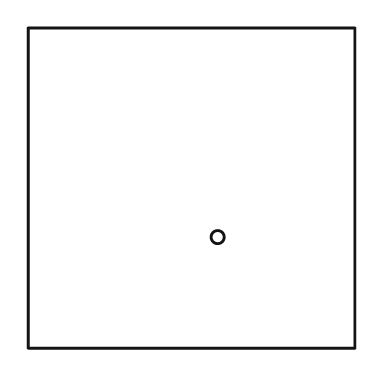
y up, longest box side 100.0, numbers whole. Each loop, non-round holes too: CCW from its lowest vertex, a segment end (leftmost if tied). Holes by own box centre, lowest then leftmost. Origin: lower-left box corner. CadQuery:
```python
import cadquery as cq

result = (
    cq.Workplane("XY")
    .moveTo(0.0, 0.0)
    .lineTo(100.0, 0.0)
    .lineTo(100.0, 98.0)
    .lineTo(0.0, 98.0)
    .close()
    .moveTo(58.0, 34.0)
    .circle(2.0)
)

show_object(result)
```